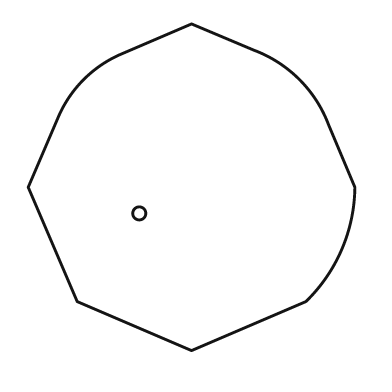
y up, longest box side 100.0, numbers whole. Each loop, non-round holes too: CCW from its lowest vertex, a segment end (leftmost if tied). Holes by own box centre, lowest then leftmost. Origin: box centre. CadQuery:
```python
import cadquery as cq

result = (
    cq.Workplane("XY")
    .moveTo(0.0, -50.0)
    .lineTo(35.0, -35.0)
    .threePointArc((46.0, -19.0), (50.0, 0.0))
    .lineTo(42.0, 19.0)
    .threePointArc((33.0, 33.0), (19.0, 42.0))
    .lineTo(0.0, 50.0)
    .lineTo(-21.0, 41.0)
    .threePointArc((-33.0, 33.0), (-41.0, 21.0))
    .lineTo(-50.0, 0.0)
    .lineTo(-35.0, -35.0)
    .close()
    .moveTo(-16.0, -8.0)
    .circle(2.0)
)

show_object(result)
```